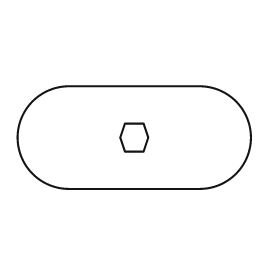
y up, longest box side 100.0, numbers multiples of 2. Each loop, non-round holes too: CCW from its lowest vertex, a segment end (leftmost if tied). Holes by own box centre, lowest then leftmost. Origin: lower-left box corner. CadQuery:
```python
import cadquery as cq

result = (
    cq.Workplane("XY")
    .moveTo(22.0, 0.0)
    .lineTo(78.0, 0.0)
    .threePointArc((100.0, 22.0), (78.0, 44.0))
    .lineTo(22.0, 44.0)
    .threePointArc((0.0, 22.0), (22.0, 0.0))
    .close()
    .moveTo(46.0, 16.0)
    .lineTo(54.0, 16.0)
    .lineTo(56.0, 22.0)
    .lineTo(54.0, 28.0)
    .lineTo(46.0, 28.0)
    .lineTo(44.0, 22.0)
    .close()
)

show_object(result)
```